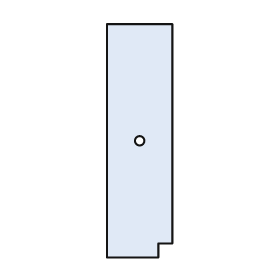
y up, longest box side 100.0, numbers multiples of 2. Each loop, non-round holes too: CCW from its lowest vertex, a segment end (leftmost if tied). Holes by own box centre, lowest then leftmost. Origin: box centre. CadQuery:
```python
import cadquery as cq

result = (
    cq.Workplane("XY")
    .moveTo(-14.0, -50.0)
    .lineTo(8.0, -50.0)
    .lineTo(8.0, -44.0)
    .lineTo(14.0, -44.0)
    .lineTo(14.0, 50.0)
    .lineTo(-14.0, 50.0)
    .close()
    .moveTo(0.0, 0.0)
    .circle(2.0)
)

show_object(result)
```